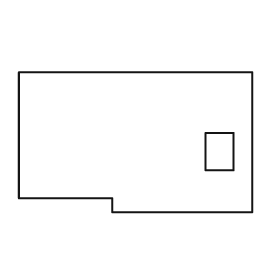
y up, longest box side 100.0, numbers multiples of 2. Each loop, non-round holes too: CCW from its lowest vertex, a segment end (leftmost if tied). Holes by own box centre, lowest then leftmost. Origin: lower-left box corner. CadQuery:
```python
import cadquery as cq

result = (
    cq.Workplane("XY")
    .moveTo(40.0, 0.0)
    .lineTo(100.0, 0.0)
    .lineTo(100.0, 60.0)
    .lineTo(0.0, 60.0)
    .lineTo(0.0, 6.0)
    .lineTo(40.0, 6.0)
    .close()
    .moveTo(80.0, 18.0)
    .lineTo(92.0, 18.0)
    .lineTo(92.0, 34.0)
    .lineTo(80.0, 34.0)
    .close()
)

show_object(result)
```